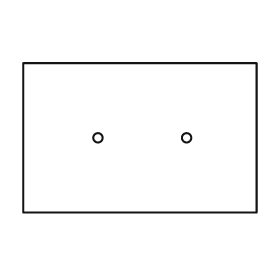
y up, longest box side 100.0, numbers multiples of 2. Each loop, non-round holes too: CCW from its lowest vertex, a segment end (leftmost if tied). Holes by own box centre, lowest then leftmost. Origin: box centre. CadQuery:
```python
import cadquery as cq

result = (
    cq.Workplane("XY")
    .moveTo(-50.0, -32.0)
    .lineTo(50.0, -32.0)
    .lineTo(50.0, 32.0)
    .lineTo(-50.0, 32.0)
    .close()
    .moveTo(-18.0, 0.0)
    .circle(2.0)
    .moveTo(20.0, 0.0)
    .circle(2.0)
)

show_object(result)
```